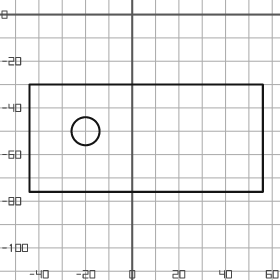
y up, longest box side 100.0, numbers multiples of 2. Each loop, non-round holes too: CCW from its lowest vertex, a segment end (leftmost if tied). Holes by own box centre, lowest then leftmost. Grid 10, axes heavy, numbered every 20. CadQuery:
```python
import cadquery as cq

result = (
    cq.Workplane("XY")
    .moveTo(-44.0, -76.0)
    .lineTo(56.0, -76.0)
    .lineTo(56.0, -30.0)
    .lineTo(-44.0, -30.0)
    .close()
    .moveTo(-20.0, -50.0)
    .circle(6.0)
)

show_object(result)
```